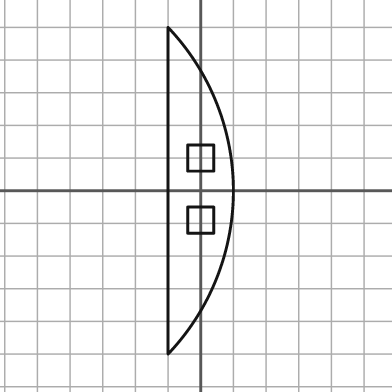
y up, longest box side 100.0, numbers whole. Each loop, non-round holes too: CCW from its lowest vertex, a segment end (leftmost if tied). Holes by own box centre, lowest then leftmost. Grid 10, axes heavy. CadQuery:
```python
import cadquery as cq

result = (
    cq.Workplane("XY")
    .moveTo(-10.0, -50.0)
    .threePointArc((10.0, 0.0), (-10.0, 50.0))
    .close()
    .moveTo(-4.0, -13.0)
    .lineTo(4.0, -13.0)
    .lineTo(4.0, -5.0)
    .lineTo(-4.0, -5.0)
    .close()
    .moveTo(-4.0, 6.0)
    .lineTo(4.0, 6.0)
    .lineTo(4.0, 14.0)
    .lineTo(-4.0, 14.0)
    .close()
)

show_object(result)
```